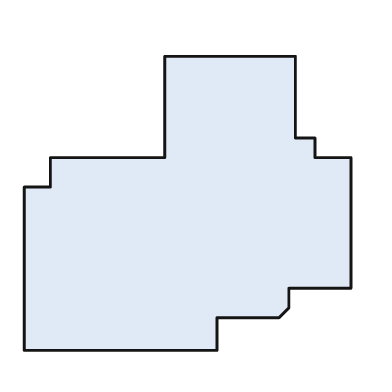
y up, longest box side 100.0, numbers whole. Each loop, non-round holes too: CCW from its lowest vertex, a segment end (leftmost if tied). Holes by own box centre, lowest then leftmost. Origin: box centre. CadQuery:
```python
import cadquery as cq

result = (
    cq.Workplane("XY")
    .moveTo(-50.0, -45.0)
    .lineTo(9.0, -45.0)
    .lineTo(9.0, -35.0)
    .lineTo(28.0, -35.0)
    .lineTo(31.0, -32.0)
    .lineTo(31.0, -26.0)
    .lineTo(50.0, -26.0)
    .lineTo(50.0, 14.0)
    .lineTo(39.0, 14.0)
    .lineTo(39.0, 20.0)
    .lineTo(33.0, 20.0)
    .lineTo(33.0, 45.0)
    .lineTo(-7.0, 45.0)
    .lineTo(-7.0, 14.0)
    .lineTo(-42.0, 14.0)
    .lineTo(-42.0, 5.0)
    .lineTo(-50.0, 5.0)
    .close()
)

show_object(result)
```